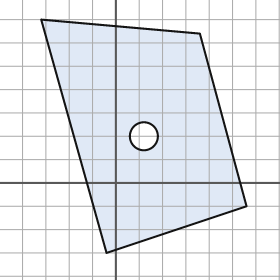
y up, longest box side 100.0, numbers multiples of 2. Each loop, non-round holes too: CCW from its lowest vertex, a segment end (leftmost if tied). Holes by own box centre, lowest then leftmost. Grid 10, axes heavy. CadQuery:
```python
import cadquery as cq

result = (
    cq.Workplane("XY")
    .moveTo(-4.0, -30.0)
    .lineTo(56.0, -10.0)
    .lineTo(36.0, 64.0)
    .lineTo(-32.0, 70.0)
    .close()
    .moveTo(12.0, 20.0)
    .circle(6.0)
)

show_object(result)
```